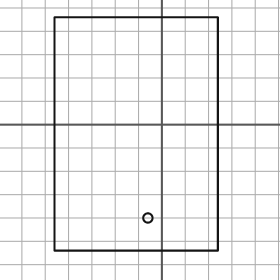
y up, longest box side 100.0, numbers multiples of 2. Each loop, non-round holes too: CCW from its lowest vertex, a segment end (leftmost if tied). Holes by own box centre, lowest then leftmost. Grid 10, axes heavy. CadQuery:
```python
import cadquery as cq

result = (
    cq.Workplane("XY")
    .moveTo(-46.0, -54.0)
    .lineTo(24.0, -54.0)
    .lineTo(24.0, 46.0)
    .lineTo(-46.0, 46.0)
    .close()
    .moveTo(-6.0, -40.0)
    .circle(2.0)
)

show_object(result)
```